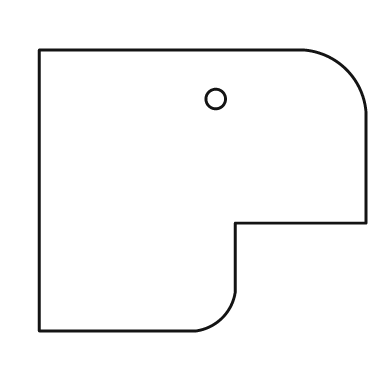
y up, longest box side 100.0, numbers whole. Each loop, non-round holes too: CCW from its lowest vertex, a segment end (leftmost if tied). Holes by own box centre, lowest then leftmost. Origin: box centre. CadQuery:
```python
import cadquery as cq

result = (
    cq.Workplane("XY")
    .moveTo(-50.0, -43.0)
    .lineTo(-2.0, -43.0)
    .threePointArc((6.0, -39.0), (10.0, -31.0))
    .lineTo(10.0, -10.0)
    .lineTo(50.0, -10.0)
    .lineTo(50.0, 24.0)
    .threePointArc((44.0, 37.0), (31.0, 43.0))
    .lineTo(-50.0, 43.0)
    .close()
    .moveTo(4.0, 28.0)
    .circle(3.0)
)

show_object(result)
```